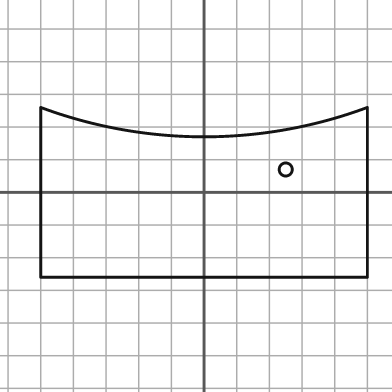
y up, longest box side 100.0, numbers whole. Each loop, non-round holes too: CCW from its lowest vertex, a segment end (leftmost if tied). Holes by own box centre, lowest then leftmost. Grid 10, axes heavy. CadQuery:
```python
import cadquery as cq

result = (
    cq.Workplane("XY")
    .moveTo(-50.0, -26.0)
    .lineTo(50.0, -26.0)
    .lineTo(50.0, 26.0)
    .threePointArc((0.0, 17.0), (-50.0, 26.0))
    .close()
    .moveTo(25.0, 7.0)
    .circle(2.0)
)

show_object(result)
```